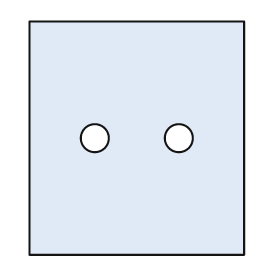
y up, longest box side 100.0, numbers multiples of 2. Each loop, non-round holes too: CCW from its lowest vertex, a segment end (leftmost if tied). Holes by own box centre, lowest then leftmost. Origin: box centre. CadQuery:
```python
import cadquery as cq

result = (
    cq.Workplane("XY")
    .moveTo(-46.0, -50.0)
    .lineTo(46.0, -50.0)
    .lineTo(46.0, 50.0)
    .lineTo(-46.0, 50.0)
    .close()
    .moveTo(-18.0, 0.0)
    .circle(6.0)
    .moveTo(18.0, 0.0)
    .circle(6.0)
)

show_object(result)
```